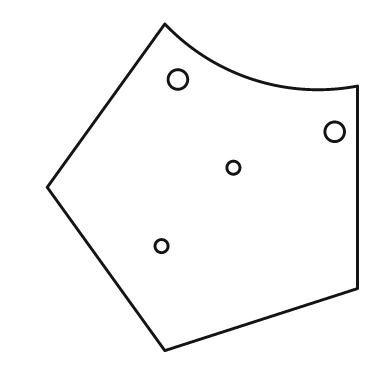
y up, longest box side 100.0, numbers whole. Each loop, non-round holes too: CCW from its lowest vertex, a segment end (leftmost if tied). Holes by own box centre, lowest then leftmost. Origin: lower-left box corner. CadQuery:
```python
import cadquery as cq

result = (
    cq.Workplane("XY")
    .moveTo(36.0, 0.0)
    .lineTo(95.0, 19.0)
    .lineTo(95.0, 81.0)
    .threePointArc((63.0, 83.0), (36.0, 100.0))
    .lineTo(0.0, 50.0)
    .close()
    .moveTo(35.0, 32.0)
    .circle(2.0)
    .moveTo(57.0, 56.0)
    .circle(2.0)
    .moveTo(88.0, 67.0)
    .circle(3.0)
    .moveTo(40.0, 83.0)
    .circle(3.0)
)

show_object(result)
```